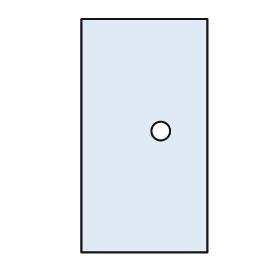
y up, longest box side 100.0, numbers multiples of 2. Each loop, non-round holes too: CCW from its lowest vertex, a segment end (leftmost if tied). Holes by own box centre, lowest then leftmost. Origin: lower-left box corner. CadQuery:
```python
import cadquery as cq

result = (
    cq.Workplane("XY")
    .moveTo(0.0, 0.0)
    .lineTo(54.0, 0.0)
    .lineTo(54.0, 100.0)
    .lineTo(0.0, 100.0)
    .close()
    .moveTo(34.0, 52.0)
    .circle(4.0)
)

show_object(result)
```